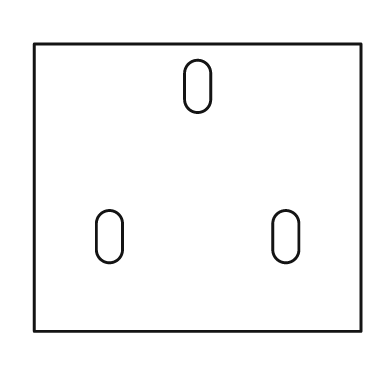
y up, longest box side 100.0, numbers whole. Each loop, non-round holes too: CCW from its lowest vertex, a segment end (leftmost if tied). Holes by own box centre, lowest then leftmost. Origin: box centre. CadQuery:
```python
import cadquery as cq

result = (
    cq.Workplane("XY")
    .moveTo(-50.0, -44.0)
    .lineTo(50.0, -44.0)
    .lineTo(50.0, 44.0)
    .lineTo(-50.0, 44.0)
    .close()
    .moveTo(-31.0, -19.0)
    .threePointArc((-27.0, -23.0), (-23.0, -19.0))
    .lineTo(-23.0, -11.0)
    .threePointArc((-27.0, -7.0), (-31.0, -11.0))
    .close()
    .moveTo(23.0, -19.0)
    .threePointArc((27.0, -23.0), (31.0, -19.0))
    .lineTo(31.0, -11.0)
    .threePointArc((27.0, -7.0), (23.0, -11.0))
    .close()
    .moveTo(-4.0, 27.0)
    .threePointArc((0.0, 23.0), (4.0, 27.0))
    .lineTo(4.0, 35.0)
    .threePointArc((0.0, 39.0), (-4.0, 35.0))
    .close()
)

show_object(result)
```